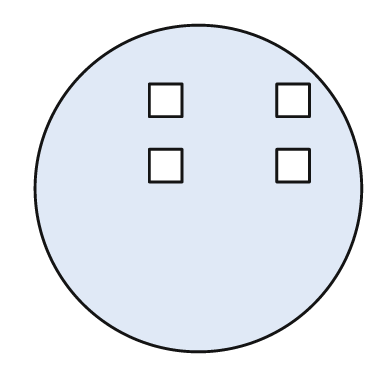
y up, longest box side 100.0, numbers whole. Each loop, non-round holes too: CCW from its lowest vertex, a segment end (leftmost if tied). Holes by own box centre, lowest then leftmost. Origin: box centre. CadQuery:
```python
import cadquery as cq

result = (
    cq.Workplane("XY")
    .moveTo(0.0, 0.0)
    .circle(50.0)
    .moveTo(-15.0, 2.0)
    .lineTo(-5.0, 2.0)
    .lineTo(-5.0, 12.0)
    .lineTo(-15.0, 12.0)
    .close()
    .moveTo(24.0, 2.0)
    .lineTo(34.0, 2.0)
    .lineTo(34.0, 12.0)
    .lineTo(24.0, 12.0)
    .close()
    .moveTo(-15.0, 22.0)
    .lineTo(-5.0, 22.0)
    .lineTo(-5.0, 32.0)
    .lineTo(-15.0, 32.0)
    .close()
    .moveTo(24.0, 22.0)
    .lineTo(34.0, 22.0)
    .lineTo(34.0, 32.0)
    .lineTo(24.0, 32.0)
    .close()
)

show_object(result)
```